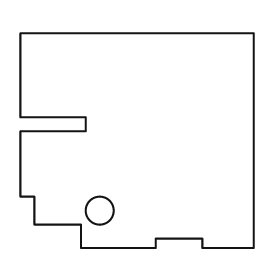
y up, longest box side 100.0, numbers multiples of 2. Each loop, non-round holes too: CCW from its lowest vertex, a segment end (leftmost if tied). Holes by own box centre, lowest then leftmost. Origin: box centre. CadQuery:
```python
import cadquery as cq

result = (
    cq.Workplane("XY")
    .moveTo(-24.0, -46.0)
    .lineTo(8.0, -46.0)
    .lineTo(8.0, -42.0)
    .lineTo(28.0, -42.0)
    .lineTo(28.0, -46.0)
    .lineTo(50.0, -46.0)
    .lineTo(50.0, 46.0)
    .lineTo(-50.0, 46.0)
    .lineTo(-50.0, 10.0)
    .lineTo(-22.0, 10.0)
    .lineTo(-22.0, 4.0)
    .lineTo(-50.0, 4.0)
    .lineTo(-50.0, -24.0)
    .lineTo(-44.0, -24.0)
    .lineTo(-44.0, -36.0)
    .lineTo(-24.0, -36.0)
    .close()
    .moveTo(-16.0, -30.0)
    .circle(6.0)
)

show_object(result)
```